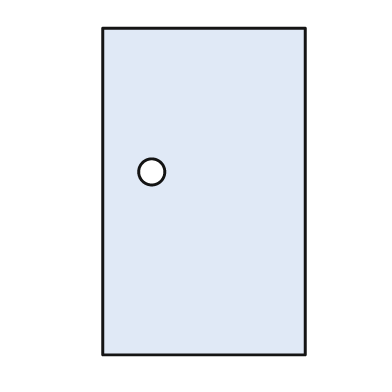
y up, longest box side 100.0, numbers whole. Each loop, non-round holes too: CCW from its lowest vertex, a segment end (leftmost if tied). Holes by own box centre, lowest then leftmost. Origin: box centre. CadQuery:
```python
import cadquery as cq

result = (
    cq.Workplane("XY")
    .moveTo(-31.0, -50.0)
    .lineTo(31.0, -50.0)
    .lineTo(31.0, 50.0)
    .lineTo(-31.0, 50.0)
    .close()
    .moveTo(-16.0, 6.0)
    .circle(4.0)
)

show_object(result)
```